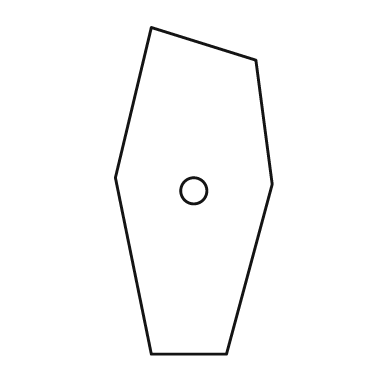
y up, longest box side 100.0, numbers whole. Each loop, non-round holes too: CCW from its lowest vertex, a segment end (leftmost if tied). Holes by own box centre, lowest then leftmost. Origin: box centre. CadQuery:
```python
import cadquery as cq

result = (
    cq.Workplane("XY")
    .moveTo(-13.0, -50.0)
    .lineTo(10.0, -50.0)
    .lineTo(24.0, 2.0)
    .lineTo(19.0, 40.0)
    .lineTo(-13.0, 50.0)
    .lineTo(-24.0, 4.0)
    .close()
    .moveTo(0.0, 0.0)
    .circle(4.0)
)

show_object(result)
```